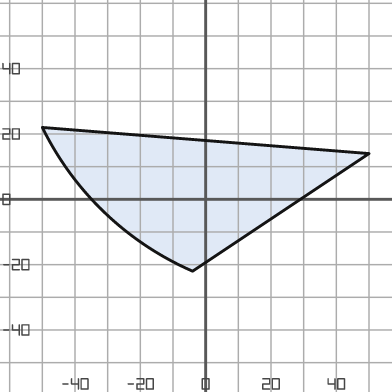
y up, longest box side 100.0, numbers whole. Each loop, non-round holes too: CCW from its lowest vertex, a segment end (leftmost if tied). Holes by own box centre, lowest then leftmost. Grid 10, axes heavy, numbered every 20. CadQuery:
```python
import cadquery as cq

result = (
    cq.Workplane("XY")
    .moveTo(-4.0, -22.0)
    .lineTo(50.0, 14.0)
    .lineTo(-50.0, 22.0)
    .threePointArc((-31.0, -4.0), (-4.0, -22.0))
    .close()
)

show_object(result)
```